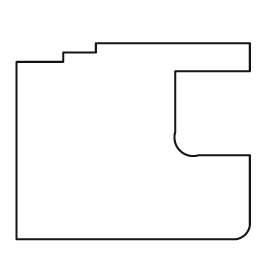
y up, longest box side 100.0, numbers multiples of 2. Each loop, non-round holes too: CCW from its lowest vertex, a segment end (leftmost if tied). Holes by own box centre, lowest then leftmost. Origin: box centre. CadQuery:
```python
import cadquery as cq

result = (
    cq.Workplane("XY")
    .moveTo(-50.0, -42.0)
    .lineTo(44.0, -42.0)
    .threePointArc((48.0, -40.0), (50.0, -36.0))
    .lineTo(50.0, -6.0)
    .lineTo(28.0, -6.0)
    .threePointArc((20.0, -4.0), (18.0, 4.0))
    .lineTo(18.0, 30.0)
    .lineTo(50.0, 30.0)
    .lineTo(50.0, 42.0)
    .lineTo(-16.0, 42.0)
    .lineTo(-16.0, 38.0)
    .lineTo(-30.0, 38.0)
    .lineTo(-30.0, 34.0)
    .lineTo(-50.0, 34.0)
    .close()
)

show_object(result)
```